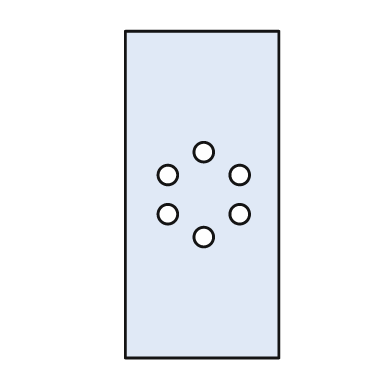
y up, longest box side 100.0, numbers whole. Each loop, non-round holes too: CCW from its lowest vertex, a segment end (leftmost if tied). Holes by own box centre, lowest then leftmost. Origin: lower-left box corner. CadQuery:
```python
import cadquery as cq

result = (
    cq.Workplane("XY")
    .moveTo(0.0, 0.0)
    .lineTo(47.0, 0.0)
    .lineTo(47.0, 100.0)
    .lineTo(0.0, 100.0)
    .close()
    .moveTo(24.0, 37.0)
    .circle(3.0)
    .moveTo(13.0, 44.0)
    .circle(3.0)
    .moveTo(35.0, 44.0)
    .circle(3.0)
    .moveTo(13.0, 56.0)
    .circle(3.0)
    .moveTo(35.0, 56.0)
    .circle(3.0)
    .moveTo(24.0, 63.0)
    .circle(3.0)
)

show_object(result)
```